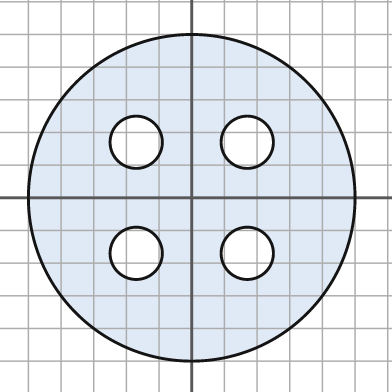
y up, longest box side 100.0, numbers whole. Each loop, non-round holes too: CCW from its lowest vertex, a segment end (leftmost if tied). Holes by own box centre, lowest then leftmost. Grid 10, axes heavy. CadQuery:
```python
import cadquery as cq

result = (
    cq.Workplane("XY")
    .moveTo(0.0, 0.0)
    .circle(50.0)
    .moveTo(-17.0, -17.0)
    .circle(8.0)
    .moveTo(17.0, -17.0)
    .circle(8.0)
    .moveTo(-17.0, 17.0)
    .circle(8.0)
    .moveTo(17.0, 17.0)
    .circle(8.0)
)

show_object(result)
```